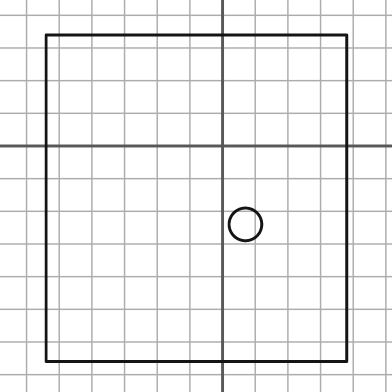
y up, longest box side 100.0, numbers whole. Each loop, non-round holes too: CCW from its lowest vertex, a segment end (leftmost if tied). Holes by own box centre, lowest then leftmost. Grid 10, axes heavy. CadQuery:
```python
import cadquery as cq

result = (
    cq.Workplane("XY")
    .moveTo(-54.0, -66.0)
    .lineTo(38.0, -66.0)
    .lineTo(38.0, 34.0)
    .lineTo(-54.0, 34.0)
    .close()
    .moveTo(7.0, -24.0)
    .circle(5.0)
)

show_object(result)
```